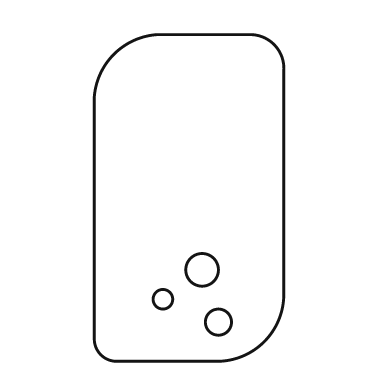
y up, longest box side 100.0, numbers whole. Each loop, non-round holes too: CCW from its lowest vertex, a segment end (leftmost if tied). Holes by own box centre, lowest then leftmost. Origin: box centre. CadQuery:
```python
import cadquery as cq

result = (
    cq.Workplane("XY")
    .moveTo(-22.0, -50.0)
    .lineTo(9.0, -50.0)
    .threePointArc((23.0, -44.0), (29.0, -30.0))
    .lineTo(29.0, 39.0)
    .threePointArc((26.0, 47.0), (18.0, 50.0))
    .lineTo(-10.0, 50.0)
    .threePointArc((-23.0, 44.0), (-29.0, 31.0))
    .lineTo(-29.0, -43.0)
    .threePointArc((-27.0, -48.0), (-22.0, -50.0))
    .close()
    .moveTo(9.0, -38.0)
    .circle(4.0)
    .moveTo(-8.0, -31.0)
    .circle(3.0)
    .moveTo(4.0, -22.0)
    .circle(5.0)
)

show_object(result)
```